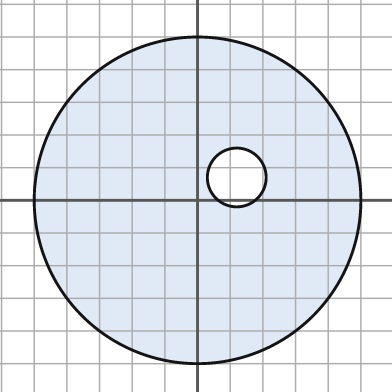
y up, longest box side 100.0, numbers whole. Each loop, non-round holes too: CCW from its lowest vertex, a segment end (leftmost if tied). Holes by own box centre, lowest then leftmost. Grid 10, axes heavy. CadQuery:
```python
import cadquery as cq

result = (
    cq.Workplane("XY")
    .moveTo(0.0, 0.0)
    .circle(50.0)
    .moveTo(12.0, 7.0)
    .circle(9.0)
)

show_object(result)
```